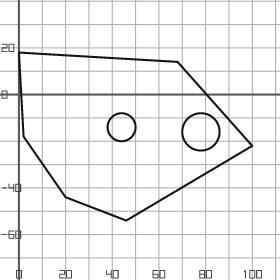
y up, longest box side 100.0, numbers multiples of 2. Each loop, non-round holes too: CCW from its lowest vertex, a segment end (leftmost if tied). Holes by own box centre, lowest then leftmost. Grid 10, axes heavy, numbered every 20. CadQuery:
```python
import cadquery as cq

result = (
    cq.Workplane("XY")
    .moveTo(46.0, -54.0)
    .lineTo(100.0, -22.0)
    .lineTo(68.0, 14.0)
    .lineTo(0.0, 18.0)
    .lineTo(2.0, -18.0)
    .lineTo(20.0, -44.0)
    .close()
    .moveTo(78.0, -16.0)
    .circle(8.0)
    .moveTo(44.0, -14.0)
    .circle(6.0)
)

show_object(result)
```